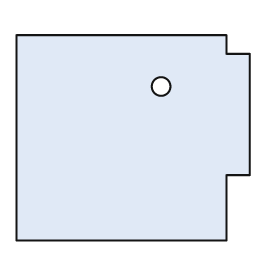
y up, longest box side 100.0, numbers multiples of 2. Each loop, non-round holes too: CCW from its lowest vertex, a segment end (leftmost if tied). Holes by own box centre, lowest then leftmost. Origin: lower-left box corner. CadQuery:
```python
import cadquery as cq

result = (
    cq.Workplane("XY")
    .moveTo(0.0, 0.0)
    .lineTo(90.0, 0.0)
    .lineTo(90.0, 28.0)
    .lineTo(100.0, 28.0)
    .lineTo(100.0, 80.0)
    .lineTo(90.0, 80.0)
    .lineTo(90.0, 88.0)
    .lineTo(0.0, 88.0)
    .close()
    .moveTo(62.0, 66.0)
    .circle(4.0)
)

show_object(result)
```